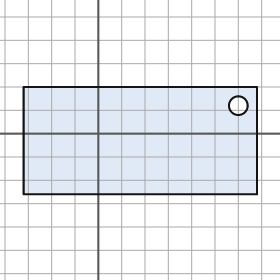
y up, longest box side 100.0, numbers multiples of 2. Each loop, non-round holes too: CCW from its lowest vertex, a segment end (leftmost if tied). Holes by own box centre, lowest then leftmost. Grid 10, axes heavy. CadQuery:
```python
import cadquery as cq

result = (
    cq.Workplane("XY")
    .moveTo(-32.0, -26.0)
    .lineTo(68.0, -26.0)
    .lineTo(68.0, 20.0)
    .lineTo(-32.0, 20.0)
    .close()
    .moveTo(60.0, 12.0)
    .circle(4.0)
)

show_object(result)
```